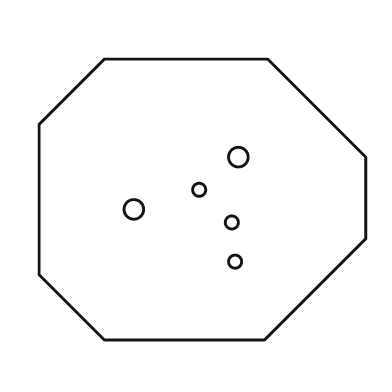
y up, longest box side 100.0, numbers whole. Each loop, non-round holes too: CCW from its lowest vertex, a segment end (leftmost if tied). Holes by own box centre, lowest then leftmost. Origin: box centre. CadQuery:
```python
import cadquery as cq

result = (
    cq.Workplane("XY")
    .moveTo(-30.0, -43.0)
    .lineTo(19.0, -43.0)
    .lineTo(50.0, -12.0)
    .lineTo(50.0, 13.0)
    .lineTo(20.0, 43.0)
    .lineTo(-30.0, 43.0)
    .lineTo(-50.0, 23.0)
    .lineTo(-50.0, -23.0)
    .close()
    .moveTo(10.0, -19.0)
    .circle(2.0)
    .moveTo(9.0, -7.0)
    .circle(2.0)
    .moveTo(-21.0, -3.0)
    .circle(3.0)
    .moveTo(-1.0, 3.0)
    .circle(2.0)
    .moveTo(11.0, 13.0)
    .circle(3.0)
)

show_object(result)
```